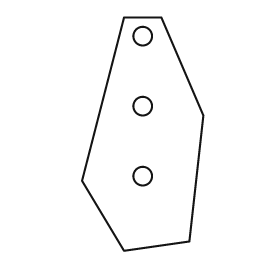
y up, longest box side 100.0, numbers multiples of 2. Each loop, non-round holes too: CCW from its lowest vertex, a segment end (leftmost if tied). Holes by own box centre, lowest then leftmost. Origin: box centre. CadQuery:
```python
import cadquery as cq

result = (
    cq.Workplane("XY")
    .moveTo(-8.0, -50.0)
    .lineTo(20.0, -46.0)
    .lineTo(26.0, 8.0)
    .lineTo(8.0, 50.0)
    .lineTo(-8.0, 50.0)
    .lineTo(-26.0, -20.0)
    .close()
    .moveTo(0.0, -18.0)
    .circle(4.0)
    .moveTo(0.0, 12.0)
    .circle(4.0)
    .moveTo(0.0, 42.0)
    .circle(4.0)
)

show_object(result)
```